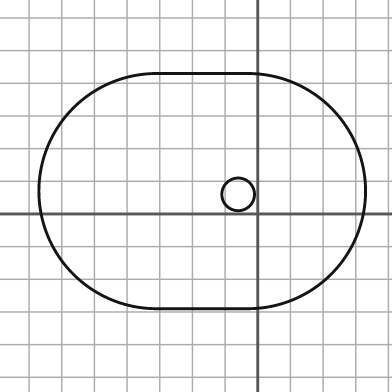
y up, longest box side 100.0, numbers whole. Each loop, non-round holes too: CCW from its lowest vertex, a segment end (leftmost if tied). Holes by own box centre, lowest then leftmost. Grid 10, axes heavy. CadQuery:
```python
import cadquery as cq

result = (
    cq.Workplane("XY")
    .moveTo(-31.0, -29.0)
    .lineTo(-3.0, -29.0)
    .threePointArc((33.0, 7.0), (-3.0, 43.0))
    .lineTo(-31.0, 43.0)
    .threePointArc((-67.0, 7.0), (-31.0, -29.0))
    .close()
    .moveTo(-6.0, 6.0)
    .circle(5.0)
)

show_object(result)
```